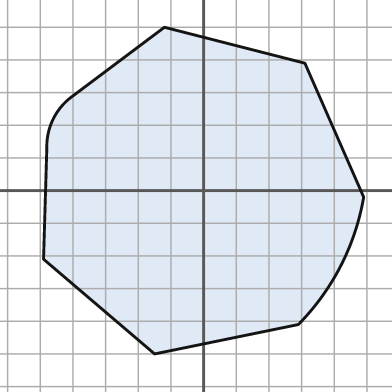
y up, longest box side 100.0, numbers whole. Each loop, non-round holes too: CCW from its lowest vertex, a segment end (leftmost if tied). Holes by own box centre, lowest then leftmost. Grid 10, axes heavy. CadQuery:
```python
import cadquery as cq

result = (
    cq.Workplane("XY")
    .moveTo(-15.0, -50.0)
    .lineTo(29.0, -41.0)
    .threePointArc((42.0, -23.0), (49.0, -2.0))
    .lineTo(31.0, 39.0)
    .lineTo(-12.0, 50.0)
    .lineTo(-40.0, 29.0)
    .threePointArc((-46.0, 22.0), (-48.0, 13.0))
    .lineTo(-49.0, -21.0)
    .close()
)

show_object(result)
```